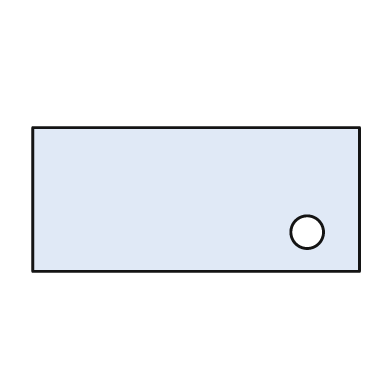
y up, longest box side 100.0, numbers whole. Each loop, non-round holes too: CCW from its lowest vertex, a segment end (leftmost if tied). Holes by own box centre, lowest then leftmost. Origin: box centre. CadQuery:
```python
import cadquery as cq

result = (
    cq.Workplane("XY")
    .moveTo(-50.0, -22.0)
    .lineTo(50.0, -22.0)
    .lineTo(50.0, 22.0)
    .lineTo(-50.0, 22.0)
    .close()
    .moveTo(34.0, -10.0)
    .circle(5.0)
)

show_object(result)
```